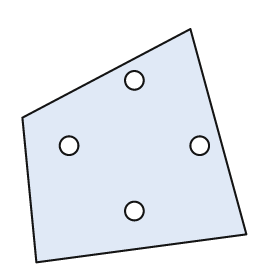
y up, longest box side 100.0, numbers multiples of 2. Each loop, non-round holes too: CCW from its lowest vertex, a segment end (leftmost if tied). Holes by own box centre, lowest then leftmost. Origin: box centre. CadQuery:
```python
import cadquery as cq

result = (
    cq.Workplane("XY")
    .moveTo(-42.0, -50.0)
    .lineTo(48.0, -38.0)
    .lineTo(24.0, 50.0)
    .lineTo(-48.0, 12.0)
    .close()
    .moveTo(0.0, -28.0)
    .circle(4.0)
    .moveTo(-28.0, 0.0)
    .circle(4.0)
    .moveTo(28.0, 0.0)
    .circle(4.0)
    .moveTo(0.0, 28.0)
    .circle(4.0)
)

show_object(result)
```